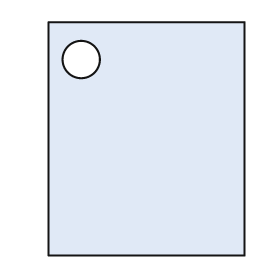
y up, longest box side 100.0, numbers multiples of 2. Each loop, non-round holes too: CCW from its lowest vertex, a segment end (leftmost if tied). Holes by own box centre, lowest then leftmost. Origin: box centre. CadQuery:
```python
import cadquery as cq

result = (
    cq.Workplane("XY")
    .moveTo(-42.0, -50.0)
    .lineTo(42.0, -50.0)
    .lineTo(42.0, 50.0)
    .lineTo(-42.0, 50.0)
    .close()
    .moveTo(-28.0, 34.0)
    .circle(8.0)
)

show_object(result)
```